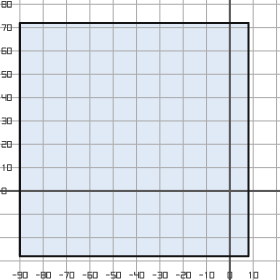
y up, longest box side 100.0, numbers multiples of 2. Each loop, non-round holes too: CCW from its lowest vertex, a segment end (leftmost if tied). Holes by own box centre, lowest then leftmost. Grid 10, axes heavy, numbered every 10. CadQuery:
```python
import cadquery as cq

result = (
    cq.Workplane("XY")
    .moveTo(-90.0, -28.0)
    .lineTo(8.0, -28.0)
    .lineTo(8.0, 72.0)
    .lineTo(-90.0, 72.0)
    .close()
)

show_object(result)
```